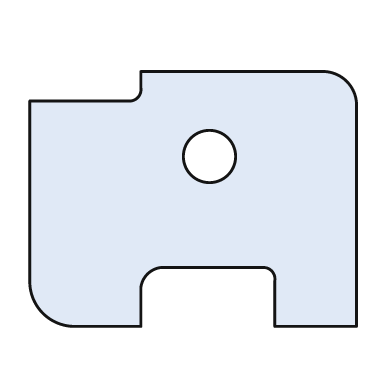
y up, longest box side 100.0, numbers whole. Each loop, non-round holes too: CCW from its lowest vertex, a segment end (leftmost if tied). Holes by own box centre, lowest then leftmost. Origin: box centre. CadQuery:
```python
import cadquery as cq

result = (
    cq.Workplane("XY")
    .moveTo(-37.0, -39.0)
    .lineTo(-16.0, -39.0)
    .lineTo(-16.0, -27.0)
    .threePointArc((-14.0, -23.0), (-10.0, -21.0))
    .lineTo(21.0, -21.0)
    .threePointArc((24.0, -22.0), (25.0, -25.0))
    .lineTo(25.0, -39.0)
    .lineTo(50.0, -39.0)
    .lineTo(50.0, 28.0)
    .threePointArc((47.0, 36.0), (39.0, 39.0))
    .lineTo(-16.0, 39.0)
    .lineTo(-16.0, 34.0)
    .threePointArc((-17.0, 31.0), (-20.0, 30.0))
    .lineTo(-50.0, 30.0)
    .lineTo(-50.0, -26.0)
    .threePointArc((-46.0, -35.0), (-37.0, -39.0))
    .close()
    .moveTo(5.0, 13.0)
    .circle(8.0)
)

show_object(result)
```